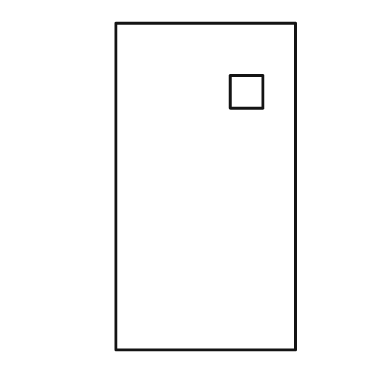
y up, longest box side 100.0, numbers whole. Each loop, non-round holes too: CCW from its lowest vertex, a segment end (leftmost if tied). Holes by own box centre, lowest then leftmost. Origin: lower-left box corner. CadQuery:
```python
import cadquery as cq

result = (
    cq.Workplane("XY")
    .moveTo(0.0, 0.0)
    .lineTo(55.0, 0.0)
    .lineTo(55.0, 100.0)
    .lineTo(0.0, 100.0)
    .close()
    .moveTo(35.0, 74.0)
    .lineTo(45.0, 74.0)
    .lineTo(45.0, 84.0)
    .lineTo(35.0, 84.0)
    .close()
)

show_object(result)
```